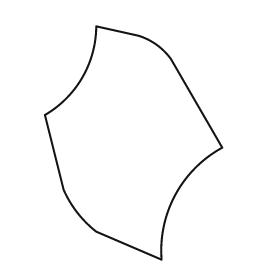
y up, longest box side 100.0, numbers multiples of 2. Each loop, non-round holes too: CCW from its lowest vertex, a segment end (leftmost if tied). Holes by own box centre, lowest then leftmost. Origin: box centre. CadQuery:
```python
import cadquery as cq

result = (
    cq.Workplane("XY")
    .moveTo(12.0, -50.0)
    .threePointArc((18.0, -22.0), (38.0, -2.0))
    .lineTo(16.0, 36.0)
    .threePointArc((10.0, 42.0), (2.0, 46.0))
    .lineTo(-16.0, 50.0)
    .threePointArc((-22.0, 28.0), (-38.0, 12.0))
    .lineTo(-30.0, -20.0)
    .threePointArc((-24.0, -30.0), (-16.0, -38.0))
    .close()
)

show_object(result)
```